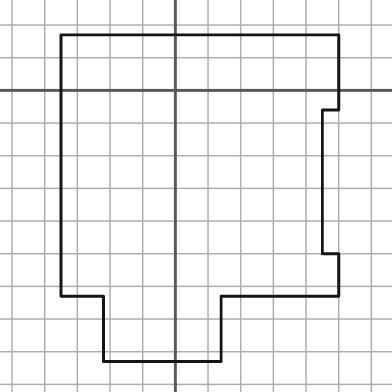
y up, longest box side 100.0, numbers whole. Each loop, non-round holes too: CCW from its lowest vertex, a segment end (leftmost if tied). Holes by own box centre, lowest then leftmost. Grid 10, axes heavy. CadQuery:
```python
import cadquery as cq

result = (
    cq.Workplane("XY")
    .moveTo(-22.0, -83.0)
    .lineTo(14.0, -83.0)
    .lineTo(14.0, -63.0)
    .lineTo(50.0, -63.0)
    .lineTo(50.0, -50.0)
    .lineTo(45.0, -50.0)
    .lineTo(45.0, -6.0)
    .lineTo(50.0, -6.0)
    .lineTo(50.0, 17.0)
    .lineTo(-35.0, 17.0)
    .lineTo(-35.0, -63.0)
    .lineTo(-22.0, -63.0)
    .close()
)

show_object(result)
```